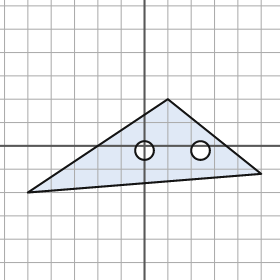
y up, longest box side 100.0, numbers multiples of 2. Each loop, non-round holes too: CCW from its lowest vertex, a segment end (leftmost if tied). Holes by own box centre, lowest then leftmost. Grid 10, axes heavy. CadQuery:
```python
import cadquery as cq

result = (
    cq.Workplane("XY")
    .moveTo(-50.0, -20.0)
    .lineTo(50.0, -12.0)
    .lineTo(10.0, 20.0)
    .close()
    .moveTo(0.0, -2.0)
    .circle(4.0)
    .moveTo(24.0, -2.0)
    .circle(4.0)
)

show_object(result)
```